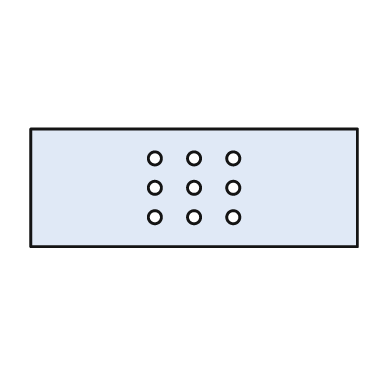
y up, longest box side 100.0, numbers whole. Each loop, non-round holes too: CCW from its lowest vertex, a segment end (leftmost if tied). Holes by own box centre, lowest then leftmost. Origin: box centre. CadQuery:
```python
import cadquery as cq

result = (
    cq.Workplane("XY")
    .moveTo(-50.0, -18.0)
    .lineTo(50.0, -18.0)
    .lineTo(50.0, 18.0)
    .lineTo(-50.0, 18.0)
    .close()
    .moveTo(-12.0, -9.0)
    .circle(2.0)
    .moveTo(0.0, -9.0)
    .circle(2.0)
    .moveTo(12.0, -9.0)
    .circle(2.0)
    .moveTo(-12.0, 0.0)
    .circle(2.0)
    .moveTo(0.0, 0.0)
    .circle(2.0)
    .moveTo(12.0, 0.0)
    .circle(2.0)
    .moveTo(-12.0, 9.0)
    .circle(2.0)
    .moveTo(0.0, 9.0)
    .circle(2.0)
    .moveTo(12.0, 9.0)
    .circle(2.0)
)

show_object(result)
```